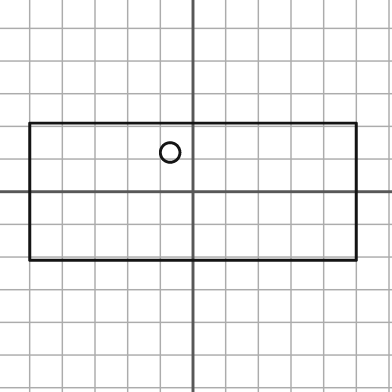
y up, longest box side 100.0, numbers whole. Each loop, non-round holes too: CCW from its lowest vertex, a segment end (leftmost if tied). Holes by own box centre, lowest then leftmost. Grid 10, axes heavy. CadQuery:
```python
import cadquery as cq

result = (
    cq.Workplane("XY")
    .moveTo(-50.0, -21.0)
    .lineTo(50.0, -21.0)
    .lineTo(50.0, 21.0)
    .lineTo(-50.0, 21.0)
    .close()
    .moveTo(-7.0, 12.0)
    .circle(3.0)
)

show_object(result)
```